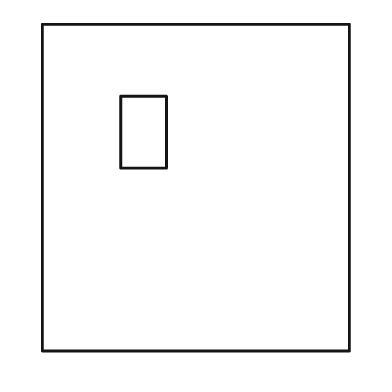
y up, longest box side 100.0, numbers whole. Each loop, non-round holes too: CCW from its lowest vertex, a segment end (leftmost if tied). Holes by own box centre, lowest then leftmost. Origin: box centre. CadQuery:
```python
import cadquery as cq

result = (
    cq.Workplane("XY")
    .moveTo(-47.0, -50.0)
    .lineTo(47.0, -50.0)
    .lineTo(47.0, 50.0)
    .lineTo(-47.0, 50.0)
    .close()
    .moveTo(-23.0, 6.0)
    .lineTo(-9.0, 6.0)
    .lineTo(-9.0, 28.0)
    .lineTo(-23.0, 28.0)
    .close()
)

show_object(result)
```